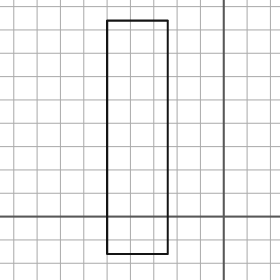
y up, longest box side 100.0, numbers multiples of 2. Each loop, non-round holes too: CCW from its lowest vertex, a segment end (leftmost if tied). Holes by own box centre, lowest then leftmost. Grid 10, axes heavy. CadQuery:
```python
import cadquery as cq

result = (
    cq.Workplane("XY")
    .moveTo(-50.0, -16.0)
    .lineTo(-24.0, -16.0)
    .lineTo(-24.0, 84.0)
    .lineTo(-50.0, 84.0)
    .close()
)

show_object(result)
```